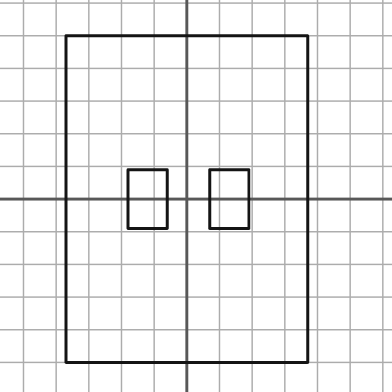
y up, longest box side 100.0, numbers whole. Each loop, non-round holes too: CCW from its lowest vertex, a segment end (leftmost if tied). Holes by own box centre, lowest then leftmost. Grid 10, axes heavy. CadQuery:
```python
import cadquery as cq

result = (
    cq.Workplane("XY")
    .moveTo(-37.0, -50.0)
    .lineTo(37.0, -50.0)
    .lineTo(37.0, 50.0)
    .lineTo(-37.0, 50.0)
    .close()
    .moveTo(-18.0, -9.0)
    .lineTo(-6.0, -9.0)
    .lineTo(-6.0, 9.0)
    .lineTo(-18.0, 9.0)
    .close()
    .moveTo(7.0, -9.0)
    .lineTo(19.0, -9.0)
    .lineTo(19.0, 9.0)
    .lineTo(7.0, 9.0)
    .close()
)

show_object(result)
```